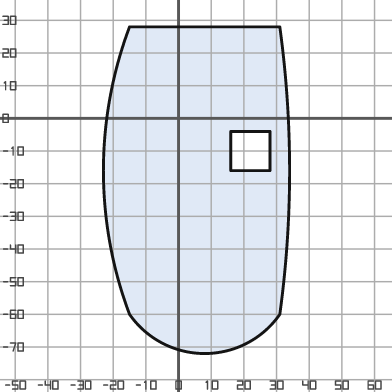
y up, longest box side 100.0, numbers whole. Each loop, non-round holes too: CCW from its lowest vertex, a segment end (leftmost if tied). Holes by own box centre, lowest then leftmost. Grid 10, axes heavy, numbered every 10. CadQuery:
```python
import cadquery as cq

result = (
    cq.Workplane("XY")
    .moveTo(-15.0, -60.0)
    .threePointArc((8.0, -72.0), (31.0, -60.0))
    .threePointArc((34.0, -16.0), (31.0, 28.0))
    .lineTo(-15.0, 28.0)
    .threePointArc((-23.0, -16.0), (-15.0, -60.0))
    .close()
    .moveTo(16.0, -16.0)
    .lineTo(28.0, -16.0)
    .lineTo(28.0, -4.0)
    .lineTo(16.0, -4.0)
    .close()
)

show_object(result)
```